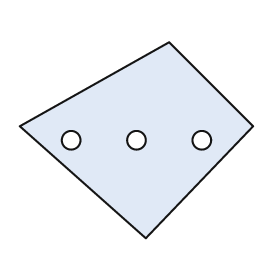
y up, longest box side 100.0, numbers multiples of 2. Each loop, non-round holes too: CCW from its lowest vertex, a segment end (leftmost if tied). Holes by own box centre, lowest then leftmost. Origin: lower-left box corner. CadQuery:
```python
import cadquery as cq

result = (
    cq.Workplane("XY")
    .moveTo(54.0, 0.0)
    .lineTo(100.0, 48.0)
    .lineTo(64.0, 84.0)
    .lineTo(0.0, 48.0)
    .close()
    .moveTo(22.0, 42.0)
    .circle(4.0)
    .moveTo(50.0, 42.0)
    .circle(4.0)
    .moveTo(78.0, 42.0)
    .circle(4.0)
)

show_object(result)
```